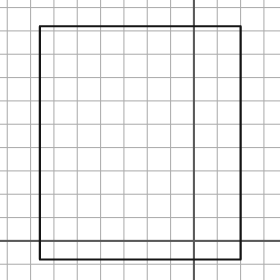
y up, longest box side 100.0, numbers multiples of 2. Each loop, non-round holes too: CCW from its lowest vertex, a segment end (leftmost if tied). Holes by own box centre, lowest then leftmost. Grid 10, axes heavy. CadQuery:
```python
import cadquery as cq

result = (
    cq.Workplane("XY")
    .moveTo(-66.0, -8.0)
    .lineTo(20.0, -8.0)
    .lineTo(20.0, 92.0)
    .lineTo(-66.0, 92.0)
    .close()
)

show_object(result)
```